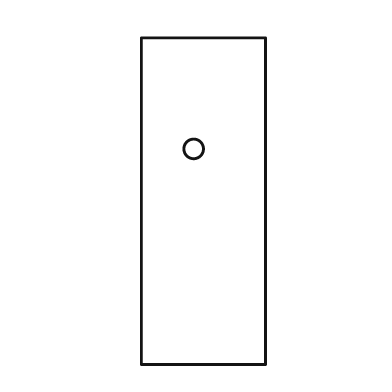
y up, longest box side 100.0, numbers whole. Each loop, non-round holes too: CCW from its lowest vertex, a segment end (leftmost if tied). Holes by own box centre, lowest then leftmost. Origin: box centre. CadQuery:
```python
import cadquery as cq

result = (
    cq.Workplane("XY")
    .moveTo(-19.0, -50.0)
    .lineTo(19.0, -50.0)
    .lineTo(19.0, 50.0)
    .lineTo(-19.0, 50.0)
    .close()
    .moveTo(-3.0, 16.0)
    .circle(3.0)
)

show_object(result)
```